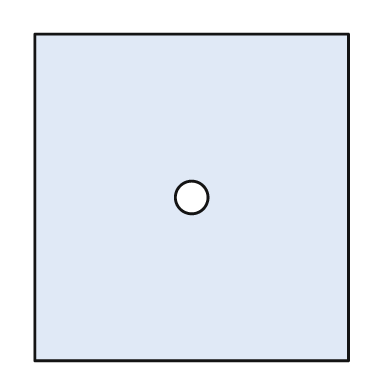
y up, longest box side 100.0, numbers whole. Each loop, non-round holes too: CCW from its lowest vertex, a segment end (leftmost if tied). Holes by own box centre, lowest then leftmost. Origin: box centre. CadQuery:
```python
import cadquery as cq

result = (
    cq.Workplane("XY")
    .moveTo(-48.0, -50.0)
    .lineTo(48.0, -50.0)
    .lineTo(48.0, 50.0)
    .lineTo(-48.0, 50.0)
    .close()
    .moveTo(0.0, 0.0)
    .circle(5.0)
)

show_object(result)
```